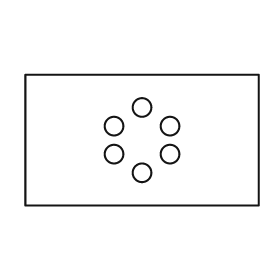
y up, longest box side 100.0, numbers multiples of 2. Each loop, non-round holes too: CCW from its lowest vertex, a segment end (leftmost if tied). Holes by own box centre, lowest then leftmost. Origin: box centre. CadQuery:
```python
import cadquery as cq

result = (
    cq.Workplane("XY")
    .moveTo(-50.0, -28.0)
    .lineTo(50.0, -28.0)
    .lineTo(50.0, 28.0)
    .lineTo(-50.0, 28.0)
    .close()
    .moveTo(0.0, -14.0)
    .circle(4.0)
    .moveTo(-12.0, -6.0)
    .circle(4.0)
    .moveTo(12.0, -6.0)
    .circle(4.0)
    .moveTo(-12.0, 6.0)
    .circle(4.0)
    .moveTo(12.0, 6.0)
    .circle(4.0)
    .moveTo(0.0, 14.0)
    .circle(4.0)
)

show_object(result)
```